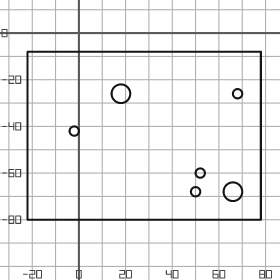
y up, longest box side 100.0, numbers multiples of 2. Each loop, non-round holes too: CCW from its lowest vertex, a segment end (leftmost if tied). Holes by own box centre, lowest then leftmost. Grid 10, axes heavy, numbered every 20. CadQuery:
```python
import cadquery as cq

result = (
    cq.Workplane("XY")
    .moveTo(-22.0, -80.0)
    .lineTo(78.0, -80.0)
    .lineTo(78.0, -8.0)
    .lineTo(-22.0, -8.0)
    .close()
    .moveTo(50.0, -68.0)
    .circle(2.0)
    .moveTo(66.0, -68.0)
    .circle(4.0)
    .moveTo(52.0, -60.0)
    .circle(2.0)
    .moveTo(-2.0, -42.0)
    .circle(2.0)
    .moveTo(18.0, -26.0)
    .circle(4.0)
    .moveTo(68.0, -26.0)
    .circle(2.0)
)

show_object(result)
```